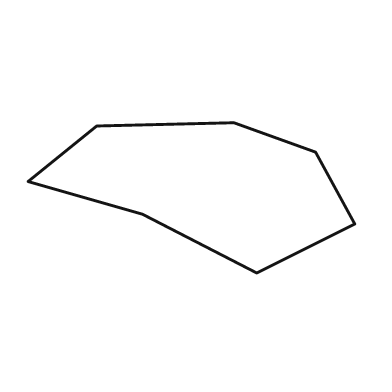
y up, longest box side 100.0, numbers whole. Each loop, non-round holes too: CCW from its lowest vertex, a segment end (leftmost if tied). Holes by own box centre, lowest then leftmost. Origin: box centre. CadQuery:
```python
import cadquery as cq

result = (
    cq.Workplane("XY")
    .moveTo(20.0, -23.0)
    .lineTo(50.0, -8.0)
    .lineTo(38.0, 14.0)
    .lineTo(13.0, 23.0)
    .lineTo(-29.0, 22.0)
    .lineTo(-50.0, 5.0)
    .lineTo(-15.0, -5.0)
    .close()
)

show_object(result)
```